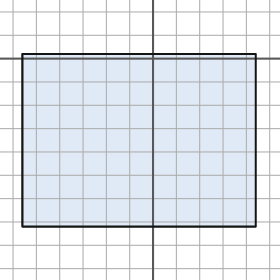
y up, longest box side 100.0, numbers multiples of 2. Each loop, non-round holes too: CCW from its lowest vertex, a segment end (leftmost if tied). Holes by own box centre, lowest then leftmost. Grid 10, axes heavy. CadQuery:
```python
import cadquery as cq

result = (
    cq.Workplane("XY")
    .moveTo(-56.0, -72.0)
    .lineTo(44.0, -72.0)
    .lineTo(44.0, 2.0)
    .lineTo(-56.0, 2.0)
    .close()
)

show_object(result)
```